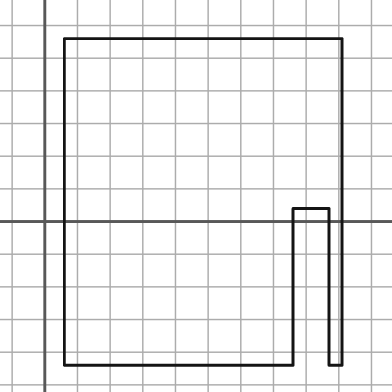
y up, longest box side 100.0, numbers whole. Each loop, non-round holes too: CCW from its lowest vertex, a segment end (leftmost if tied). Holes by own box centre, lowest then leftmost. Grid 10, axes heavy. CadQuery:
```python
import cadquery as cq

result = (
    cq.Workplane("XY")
    .moveTo(6.0, -44.0)
    .lineTo(76.0, -44.0)
    .lineTo(76.0, 4.0)
    .lineTo(87.0, 4.0)
    .lineTo(87.0, -44.0)
    .lineTo(91.0, -44.0)
    .lineTo(91.0, 56.0)
    .lineTo(6.0, 56.0)
    .close()
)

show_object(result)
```